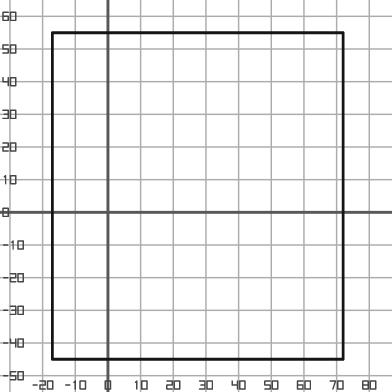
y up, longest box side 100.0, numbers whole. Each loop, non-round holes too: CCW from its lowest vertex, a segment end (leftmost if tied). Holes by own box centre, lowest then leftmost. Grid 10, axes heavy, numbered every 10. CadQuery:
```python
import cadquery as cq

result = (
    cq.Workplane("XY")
    .moveTo(-17.0, -45.0)
    .lineTo(72.0, -45.0)
    .lineTo(72.0, 55.0)
    .lineTo(-17.0, 55.0)
    .close()
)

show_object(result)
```